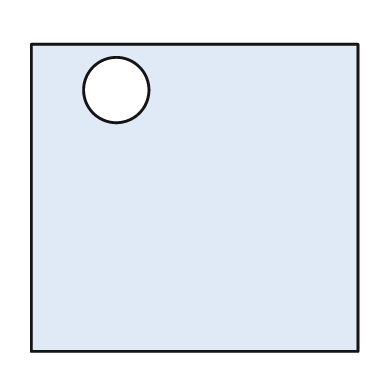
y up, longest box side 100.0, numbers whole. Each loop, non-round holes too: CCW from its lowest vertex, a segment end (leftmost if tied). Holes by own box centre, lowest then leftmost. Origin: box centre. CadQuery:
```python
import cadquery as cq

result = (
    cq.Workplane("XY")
    .moveTo(-50.0, -47.0)
    .lineTo(50.0, -47.0)
    .lineTo(50.0, 47.0)
    .lineTo(-50.0, 47.0)
    .close()
    .moveTo(-24.0, 33.0)
    .circle(10.0)
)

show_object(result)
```